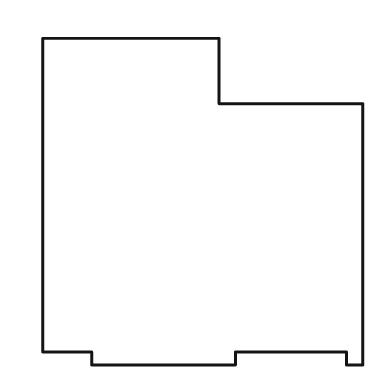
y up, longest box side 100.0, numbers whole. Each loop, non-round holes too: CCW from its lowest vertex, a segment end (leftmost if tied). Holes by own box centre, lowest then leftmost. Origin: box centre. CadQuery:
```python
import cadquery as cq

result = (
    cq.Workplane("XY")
    .moveTo(-34.0, -50.0)
    .lineTo(10.0, -50.0)
    .lineTo(10.0, -46.0)
    .lineTo(44.0, -46.0)
    .lineTo(44.0, -50.0)
    .lineTo(49.0, -50.0)
    .lineTo(49.0, 30.0)
    .lineTo(5.0, 30.0)
    .lineTo(5.0, 50.0)
    .lineTo(-49.0, 50.0)
    .lineTo(-49.0, -46.0)
    .lineTo(-34.0, -46.0)
    .close()
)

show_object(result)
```